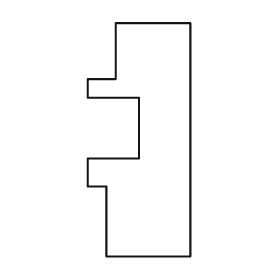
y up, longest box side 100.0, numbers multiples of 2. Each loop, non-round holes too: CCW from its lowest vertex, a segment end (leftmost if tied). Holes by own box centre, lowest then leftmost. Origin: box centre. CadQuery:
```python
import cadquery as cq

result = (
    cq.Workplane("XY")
    .moveTo(-14.0, -50.0)
    .lineTo(22.0, -50.0)
    .lineTo(22.0, 50.0)
    .lineTo(-10.0, 50.0)
    .lineTo(-10.0, 26.0)
    .lineTo(-22.0, 26.0)
    .lineTo(-22.0, 18.0)
    .lineTo(0.0, 18.0)
    .lineTo(0.0, -8.0)
    .lineTo(-22.0, -8.0)
    .lineTo(-22.0, -20.0)
    .lineTo(-14.0, -20.0)
    .close()
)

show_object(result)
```